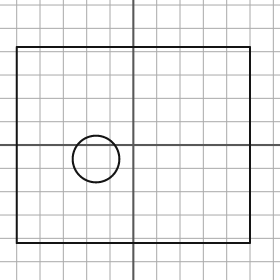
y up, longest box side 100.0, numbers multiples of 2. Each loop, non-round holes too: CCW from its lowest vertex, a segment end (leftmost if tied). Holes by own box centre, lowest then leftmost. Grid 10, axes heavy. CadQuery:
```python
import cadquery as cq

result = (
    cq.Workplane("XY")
    .moveTo(-50.0, -42.0)
    .lineTo(50.0, -42.0)
    .lineTo(50.0, 42.0)
    .lineTo(-50.0, 42.0)
    .close()
    .moveTo(-16.0, -6.0)
    .circle(10.0)
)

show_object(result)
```